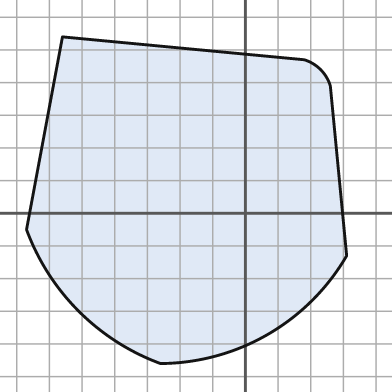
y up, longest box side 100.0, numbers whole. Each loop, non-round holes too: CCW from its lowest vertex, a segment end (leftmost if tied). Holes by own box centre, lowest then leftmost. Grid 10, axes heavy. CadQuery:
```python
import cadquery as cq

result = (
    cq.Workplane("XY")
    .moveTo(-26.0, -46.0)
    .threePointArc((7.0, -37.0), (31.0, -13.0))
    .lineTo(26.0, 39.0)
    .threePointArc((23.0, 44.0), (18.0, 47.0))
    .lineTo(-56.0, 54.0)
    .lineTo(-67.0, -5.0)
    .threePointArc((-51.0, -30.0), (-26.0, -46.0))
    .close()
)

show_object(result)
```